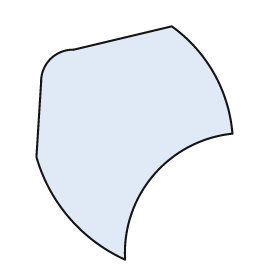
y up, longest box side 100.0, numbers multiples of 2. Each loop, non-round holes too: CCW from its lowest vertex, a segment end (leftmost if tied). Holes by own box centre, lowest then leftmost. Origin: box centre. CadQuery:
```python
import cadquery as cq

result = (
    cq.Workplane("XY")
    .moveTo(-4.0, -50.0)
    .threePointArc((8.0, -14.0), (42.0, 4.0))
    .threePointArc((34.0, 30.0), (16.0, 50.0))
    .lineTo(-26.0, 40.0)
    .threePointArc((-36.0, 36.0), (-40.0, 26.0))
    .lineTo(-42.0, -6.0)
    .threePointArc((-28.0, -32.0), (-4.0, -50.0))
    .close()
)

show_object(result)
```